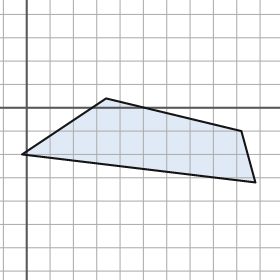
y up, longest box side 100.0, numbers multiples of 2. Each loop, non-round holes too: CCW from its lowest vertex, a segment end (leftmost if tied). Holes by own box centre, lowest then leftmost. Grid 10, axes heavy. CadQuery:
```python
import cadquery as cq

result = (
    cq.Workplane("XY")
    .moveTo(98.0, -32.0)
    .lineTo(92.0, -10.0)
    .lineTo(34.0, 4.0)
    .lineTo(-2.0, -20.0)
    .close()
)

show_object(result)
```